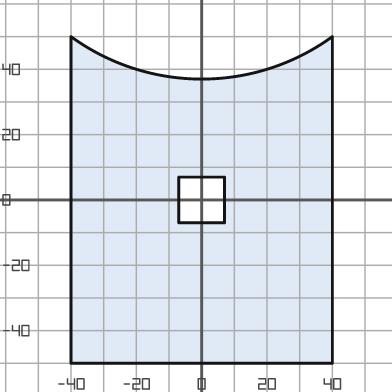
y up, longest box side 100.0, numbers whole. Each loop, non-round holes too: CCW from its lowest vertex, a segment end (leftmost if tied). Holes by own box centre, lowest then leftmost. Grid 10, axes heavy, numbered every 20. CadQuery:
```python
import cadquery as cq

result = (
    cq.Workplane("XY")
    .moveTo(-40.0, -50.0)
    .lineTo(40.0, -50.0)
    .lineTo(40.0, 50.0)
    .threePointArc((0.0, 37.0), (-40.0, 50.0))
    .close()
    .moveTo(-7.0, -7.0)
    .lineTo(7.0, -7.0)
    .lineTo(7.0, 7.0)
    .lineTo(-7.0, 7.0)
    .close()
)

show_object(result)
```